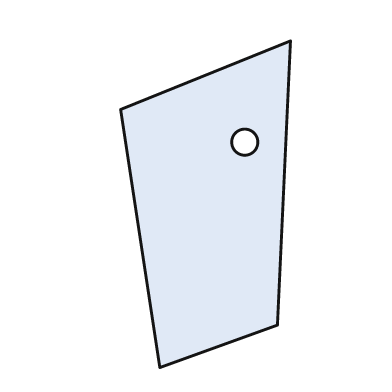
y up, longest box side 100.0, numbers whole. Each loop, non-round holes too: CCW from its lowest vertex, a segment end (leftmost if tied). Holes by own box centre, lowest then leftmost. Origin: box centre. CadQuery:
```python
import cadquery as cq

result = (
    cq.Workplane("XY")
    .moveTo(-14.0, -50.0)
    .lineTo(22.0, -37.0)
    .lineTo(26.0, 50.0)
    .lineTo(-26.0, 29.0)
    .close()
    .moveTo(12.0, 19.0)
    .circle(4.0)
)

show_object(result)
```